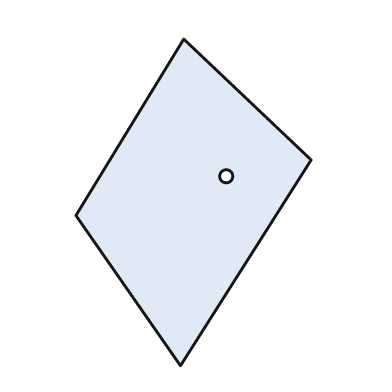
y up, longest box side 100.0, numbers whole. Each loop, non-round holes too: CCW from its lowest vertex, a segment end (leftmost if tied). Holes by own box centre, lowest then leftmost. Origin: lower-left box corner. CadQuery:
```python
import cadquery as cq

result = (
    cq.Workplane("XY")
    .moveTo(32.0, 0.0)
    .lineTo(72.0, 63.0)
    .lineTo(33.0, 100.0)
    .lineTo(0.0, 46.0)
    .close()
    .moveTo(46.0, 58.0)
    .circle(2.0)
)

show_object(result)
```